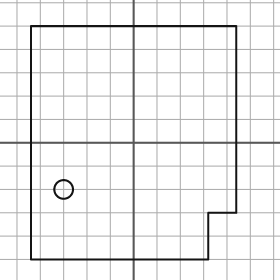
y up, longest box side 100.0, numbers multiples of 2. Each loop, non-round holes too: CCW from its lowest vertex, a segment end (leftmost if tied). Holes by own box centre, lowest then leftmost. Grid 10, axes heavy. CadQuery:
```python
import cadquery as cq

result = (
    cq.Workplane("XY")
    .moveTo(-44.0, -50.0)
    .lineTo(32.0, -50.0)
    .lineTo(32.0, -30.0)
    .lineTo(44.0, -30.0)
    .lineTo(44.0, 50.0)
    .lineTo(-44.0, 50.0)
    .close()
    .moveTo(-30.0, -20.0)
    .circle(4.0)
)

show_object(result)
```